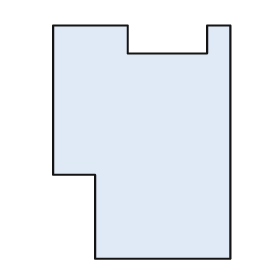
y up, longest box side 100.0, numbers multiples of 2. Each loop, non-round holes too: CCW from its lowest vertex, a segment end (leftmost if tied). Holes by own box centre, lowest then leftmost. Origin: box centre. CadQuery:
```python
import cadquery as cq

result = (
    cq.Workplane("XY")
    .moveTo(-20.0, -50.0)
    .lineTo(38.0, -50.0)
    .lineTo(38.0, 50.0)
    .lineTo(28.0, 50.0)
    .lineTo(28.0, 38.0)
    .lineTo(-6.0, 38.0)
    .lineTo(-6.0, 50.0)
    .lineTo(-38.0, 50.0)
    .lineTo(-38.0, -14.0)
    .lineTo(-20.0, -14.0)
    .close()
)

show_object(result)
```